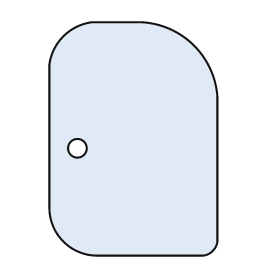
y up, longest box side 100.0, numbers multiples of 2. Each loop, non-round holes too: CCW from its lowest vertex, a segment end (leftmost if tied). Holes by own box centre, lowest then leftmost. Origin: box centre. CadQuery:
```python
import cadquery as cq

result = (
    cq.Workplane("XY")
    .moveTo(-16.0, -50.0)
    .lineTo(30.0, -50.0)
    .threePointArc((34.0, -48.0), (36.0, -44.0))
    .lineTo(36.0, 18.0)
    .threePointArc((26.0, 40.0), (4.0, 50.0))
    .lineTo(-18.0, 50.0)
    .threePointArc((-30.0, 44.0), (-36.0, 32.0))
    .lineTo(-36.0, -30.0)
    .threePointArc((-30.0, -44.0), (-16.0, -50.0))
    .close()
    .moveTo(-24.0, -4.0)
    .circle(4.0)
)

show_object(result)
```